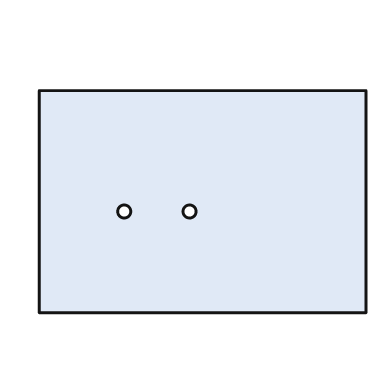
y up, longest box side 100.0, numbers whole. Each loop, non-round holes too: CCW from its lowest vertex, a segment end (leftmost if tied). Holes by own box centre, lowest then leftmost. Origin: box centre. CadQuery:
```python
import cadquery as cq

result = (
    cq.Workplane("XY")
    .moveTo(-50.0, -34.0)
    .lineTo(50.0, -34.0)
    .lineTo(50.0, 34.0)
    .lineTo(-50.0, 34.0)
    .close()
    .moveTo(-24.0, -3.0)
    .circle(2.0)
    .moveTo(-4.0, -3.0)
    .circle(2.0)
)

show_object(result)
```